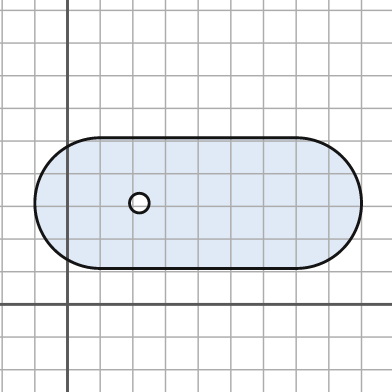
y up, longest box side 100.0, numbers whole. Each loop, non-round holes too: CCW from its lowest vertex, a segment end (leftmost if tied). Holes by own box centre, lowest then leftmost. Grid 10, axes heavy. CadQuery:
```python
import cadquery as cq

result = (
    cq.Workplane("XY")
    .moveTo(10.0, 11.0)
    .lineTo(70.0, 11.0)
    .threePointArc((90.0, 31.0), (70.0, 51.0))
    .lineTo(10.0, 51.0)
    .threePointArc((-10.0, 31.0), (10.0, 11.0))
    .close()
    .moveTo(22.0, 31.0)
    .circle(3.0)
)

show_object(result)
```